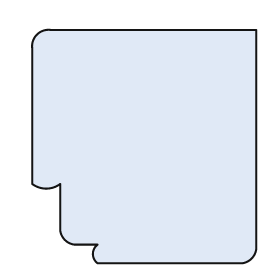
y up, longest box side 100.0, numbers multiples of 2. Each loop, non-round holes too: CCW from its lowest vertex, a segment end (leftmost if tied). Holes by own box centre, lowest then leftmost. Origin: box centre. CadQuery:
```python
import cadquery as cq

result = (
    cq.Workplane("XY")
    .moveTo(-20.0, -50.0)
    .lineTo(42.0, -50.0)
    .threePointArc((46.0, -48.0), (48.0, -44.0))
    .lineTo(48.0, 50.0)
    .lineTo(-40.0, 50.0)
    .threePointArc((-46.0, 48.0), (-48.0, 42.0))
    .lineTo(-48.0, -16.0)
    .threePointArc((-42.0, -18.0), (-36.0, -16.0))
    .lineTo(-36.0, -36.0)
    .threePointArc((-34.0, -40.0), (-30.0, -42.0))
    .lineTo(-20.0, -42.0)
    .threePointArc((-22.0, -46.0), (-20.0, -50.0))
    .close()
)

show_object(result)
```